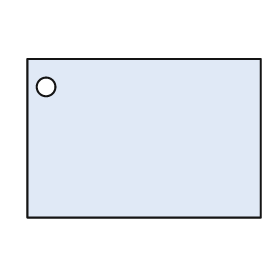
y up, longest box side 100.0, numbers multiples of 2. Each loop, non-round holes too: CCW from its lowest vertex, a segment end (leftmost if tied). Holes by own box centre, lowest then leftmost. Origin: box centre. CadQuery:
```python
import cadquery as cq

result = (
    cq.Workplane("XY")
    .moveTo(-50.0, -34.0)
    .lineTo(50.0, -34.0)
    .lineTo(50.0, 34.0)
    .lineTo(-50.0, 34.0)
    .close()
    .moveTo(-42.0, 22.0)
    .circle(4.0)
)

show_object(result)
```